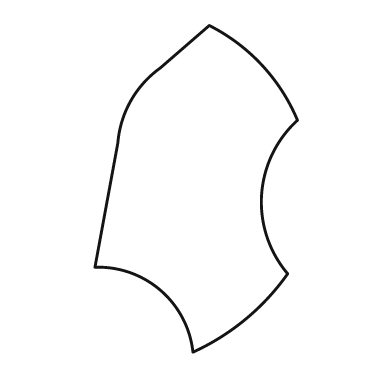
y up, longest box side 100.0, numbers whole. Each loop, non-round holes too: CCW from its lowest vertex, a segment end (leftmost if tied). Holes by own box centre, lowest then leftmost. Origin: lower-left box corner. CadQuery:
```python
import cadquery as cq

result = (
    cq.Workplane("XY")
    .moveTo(30.0, 0.0)
    .threePointArc((46.0, 10.0), (59.0, 24.0))
    .threePointArc((51.0, 48.0), (62.0, 71.0))
    .threePointArc((51.0, 88.0), (35.0, 100.0))
    .lineTo(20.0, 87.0)
    .threePointArc((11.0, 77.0), (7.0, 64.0))
    .lineTo(0.0, 26.0)
    .threePointArc((20.0, 19.0), (30.0, 0.0))
    .close()
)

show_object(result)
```